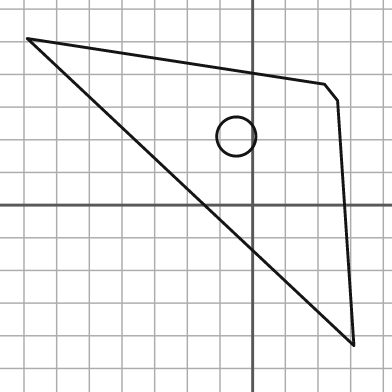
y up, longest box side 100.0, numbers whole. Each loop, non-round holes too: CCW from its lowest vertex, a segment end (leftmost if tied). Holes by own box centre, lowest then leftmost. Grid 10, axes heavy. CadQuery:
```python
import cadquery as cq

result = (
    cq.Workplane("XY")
    .moveTo(31.0, -43.0)
    .lineTo(26.0, 32.0)
    .lineTo(22.0, 37.0)
    .lineTo(-69.0, 51.0)
    .close()
    .moveTo(-5.0, 21.0)
    .circle(6.0)
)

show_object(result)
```